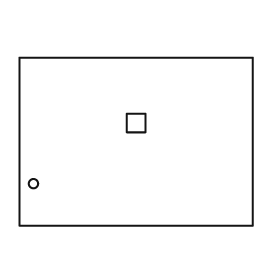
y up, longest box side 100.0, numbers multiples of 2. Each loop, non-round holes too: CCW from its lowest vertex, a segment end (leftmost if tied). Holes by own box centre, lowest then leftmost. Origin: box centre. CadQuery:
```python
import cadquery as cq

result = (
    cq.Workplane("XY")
    .moveTo(-50.0, -36.0)
    .lineTo(50.0, -36.0)
    .lineTo(50.0, 36.0)
    .lineTo(-50.0, 36.0)
    .close()
    .moveTo(-44.0, -18.0)
    .circle(2.0)
    .moveTo(-4.0, 4.0)
    .lineTo(4.0, 4.0)
    .lineTo(4.0, 12.0)
    .lineTo(-4.0, 12.0)
    .close()
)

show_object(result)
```